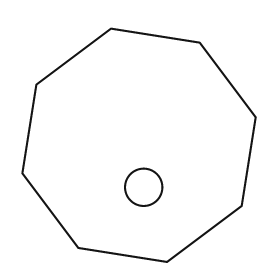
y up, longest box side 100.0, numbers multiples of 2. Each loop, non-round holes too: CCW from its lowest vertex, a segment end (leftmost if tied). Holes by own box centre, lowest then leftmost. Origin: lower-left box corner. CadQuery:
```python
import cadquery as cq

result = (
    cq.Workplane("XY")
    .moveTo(62.0, 0.0)
    .lineTo(94.0, 24.0)
    .lineTo(100.0, 62.0)
    .lineTo(76.0, 94.0)
    .lineTo(38.0, 100.0)
    .lineTo(6.0, 76.0)
    .lineTo(0.0, 38.0)
    .lineTo(24.0, 6.0)
    .close()
    .moveTo(52.0, 32.0)
    .circle(8.0)
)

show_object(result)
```